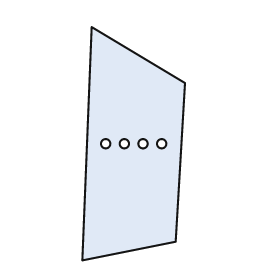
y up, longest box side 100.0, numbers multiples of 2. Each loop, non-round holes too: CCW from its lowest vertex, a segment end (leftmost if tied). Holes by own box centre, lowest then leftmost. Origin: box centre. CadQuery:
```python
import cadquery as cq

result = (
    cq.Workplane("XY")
    .moveTo(-22.0, -50.0)
    .lineTo(18.0, -42.0)
    .lineTo(22.0, 26.0)
    .lineTo(-18.0, 50.0)
    .close()
    .moveTo(-12.0, 0.0)
    .circle(2.0)
    .moveTo(-4.0, 0.0)
    .circle(2.0)
    .moveTo(4.0, 0.0)
    .circle(2.0)
    .moveTo(12.0, 0.0)
    .circle(2.0)
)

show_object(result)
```